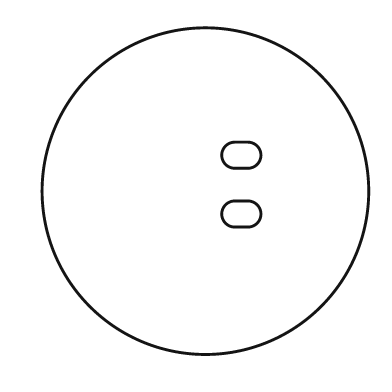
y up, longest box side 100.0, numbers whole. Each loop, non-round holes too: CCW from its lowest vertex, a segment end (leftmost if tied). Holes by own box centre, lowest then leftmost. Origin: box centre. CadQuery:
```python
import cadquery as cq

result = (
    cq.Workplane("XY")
    .moveTo(0.0, 0.0)
    .circle(50.0)
    .moveTo(9.0, -11.0)
    .lineTo(13.0, -11.0)
    .threePointArc((17.0, -7.0), (13.0, -3.0))
    .lineTo(9.0, -3.0)
    .threePointArc((5.0, -7.0), (9.0, -11.0))
    .close()
    .moveTo(9.0, 7.0)
    .lineTo(13.0, 7.0)
    .threePointArc((17.0, 11.0), (13.0, 15.0))
    .lineTo(9.0, 15.0)
    .threePointArc((5.0, 11.0), (9.0, 7.0))
    .close()
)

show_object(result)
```